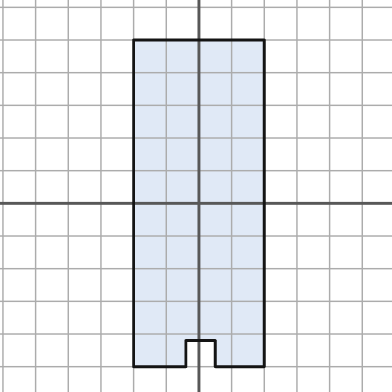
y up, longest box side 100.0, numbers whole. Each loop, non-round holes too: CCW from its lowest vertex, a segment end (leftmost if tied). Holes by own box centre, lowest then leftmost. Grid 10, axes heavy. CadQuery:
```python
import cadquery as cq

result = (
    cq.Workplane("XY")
    .moveTo(-20.0, -50.0)
    .lineTo(-4.0, -50.0)
    .lineTo(-4.0, -42.0)
    .lineTo(5.0, -42.0)
    .lineTo(5.0, -50.0)
    .lineTo(20.0, -50.0)
    .lineTo(20.0, 50.0)
    .lineTo(-20.0, 50.0)
    .close()
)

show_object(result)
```